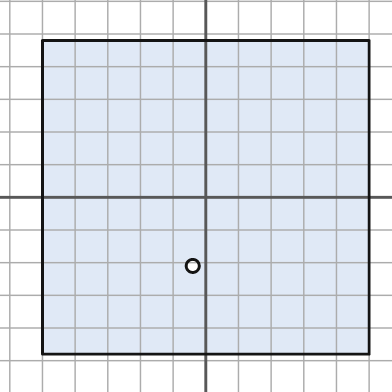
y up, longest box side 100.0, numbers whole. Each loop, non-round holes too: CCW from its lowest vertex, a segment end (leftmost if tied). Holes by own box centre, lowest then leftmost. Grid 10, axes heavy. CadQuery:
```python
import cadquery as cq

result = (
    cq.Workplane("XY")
    .moveTo(-50.0, -48.0)
    .lineTo(50.0, -48.0)
    .lineTo(50.0, 48.0)
    .lineTo(-50.0, 48.0)
    .close()
    .moveTo(-4.0, -21.0)
    .circle(2.0)
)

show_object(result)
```